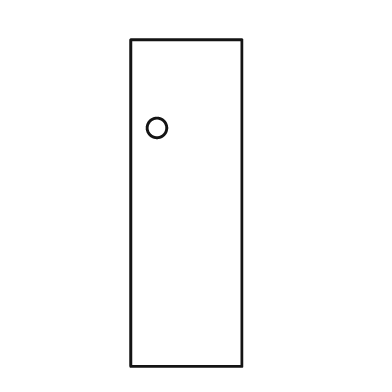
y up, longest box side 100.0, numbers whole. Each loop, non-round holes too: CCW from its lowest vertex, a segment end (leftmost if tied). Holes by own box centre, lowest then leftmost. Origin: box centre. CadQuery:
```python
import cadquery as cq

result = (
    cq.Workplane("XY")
    .moveTo(-17.0, -50.0)
    .lineTo(17.0, -50.0)
    .lineTo(17.0, 50.0)
    .lineTo(-17.0, 50.0)
    .close()
    .moveTo(-9.0, 23.0)
    .circle(3.0)
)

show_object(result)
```